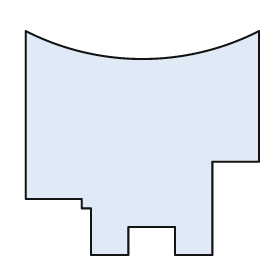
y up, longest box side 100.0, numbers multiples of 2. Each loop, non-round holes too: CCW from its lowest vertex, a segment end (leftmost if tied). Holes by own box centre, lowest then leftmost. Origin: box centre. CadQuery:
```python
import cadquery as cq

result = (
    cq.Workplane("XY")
    .moveTo(-22.0, -48.0)
    .lineTo(-6.0, -48.0)
    .lineTo(-6.0, -36.0)
    .lineTo(14.0, -36.0)
    .lineTo(14.0, -48.0)
    .lineTo(30.0, -48.0)
    .lineTo(30.0, -8.0)
    .lineTo(50.0, -8.0)
    .lineTo(50.0, 48.0)
    .threePointArc((0.0, 36.0), (-50.0, 48.0))
    .lineTo(-50.0, -24.0)
    .lineTo(-26.0, -24.0)
    .lineTo(-26.0, -28.0)
    .lineTo(-22.0, -28.0)
    .close()
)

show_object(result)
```